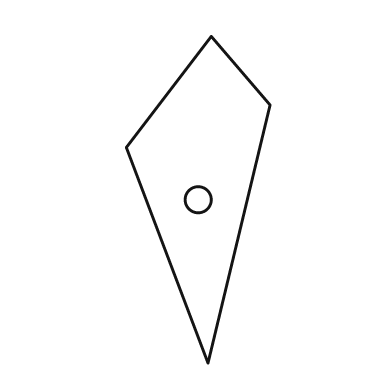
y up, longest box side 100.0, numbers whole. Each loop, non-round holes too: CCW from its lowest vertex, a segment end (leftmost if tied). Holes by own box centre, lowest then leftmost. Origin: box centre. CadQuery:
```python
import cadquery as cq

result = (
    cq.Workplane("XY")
    .moveTo(3.0, -50.0)
    .lineTo(22.0, 29.0)
    .lineTo(4.0, 50.0)
    .lineTo(-22.0, 16.0)
    .close()
    .moveTo(0.0, 0.0)
    .circle(4.0)
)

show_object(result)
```